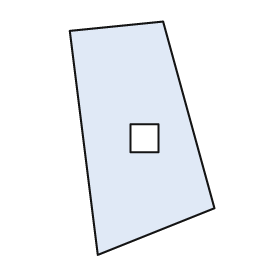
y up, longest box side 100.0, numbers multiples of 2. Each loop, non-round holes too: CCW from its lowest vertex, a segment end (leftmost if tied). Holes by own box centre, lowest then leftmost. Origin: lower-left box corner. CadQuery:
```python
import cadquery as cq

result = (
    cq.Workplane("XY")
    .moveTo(12.0, 0.0)
    .lineTo(62.0, 20.0)
    .lineTo(40.0, 100.0)
    .lineTo(0.0, 96.0)
    .close()
    .moveTo(26.0, 44.0)
    .lineTo(38.0, 44.0)
    .lineTo(38.0, 56.0)
    .lineTo(26.0, 56.0)
    .close()
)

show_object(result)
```